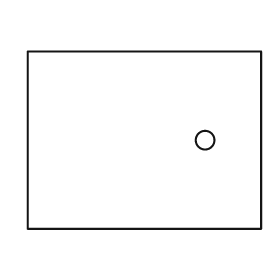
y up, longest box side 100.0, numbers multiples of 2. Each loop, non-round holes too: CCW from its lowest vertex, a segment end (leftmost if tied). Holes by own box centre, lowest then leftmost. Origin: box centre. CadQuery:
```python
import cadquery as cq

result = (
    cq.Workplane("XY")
    .moveTo(-50.0, -38.0)
    .lineTo(50.0, -38.0)
    .lineTo(50.0, 38.0)
    .lineTo(-50.0, 38.0)
    .close()
    .moveTo(26.0, 0.0)
    .circle(4.0)
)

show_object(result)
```